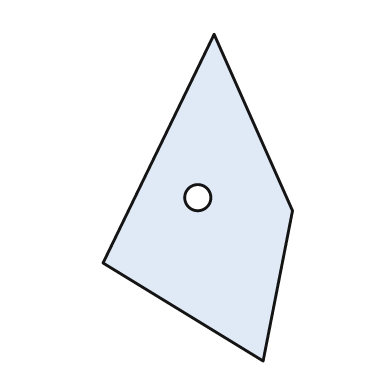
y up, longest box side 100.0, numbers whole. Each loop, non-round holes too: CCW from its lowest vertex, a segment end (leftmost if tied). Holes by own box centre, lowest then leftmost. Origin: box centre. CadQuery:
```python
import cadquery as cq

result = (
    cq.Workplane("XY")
    .moveTo(20.0, -50.0)
    .lineTo(29.0, -4.0)
    .lineTo(5.0, 50.0)
    .lineTo(-29.0, -20.0)
    .close()
    .moveTo(0.0, 0.0)
    .circle(4.0)
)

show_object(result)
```